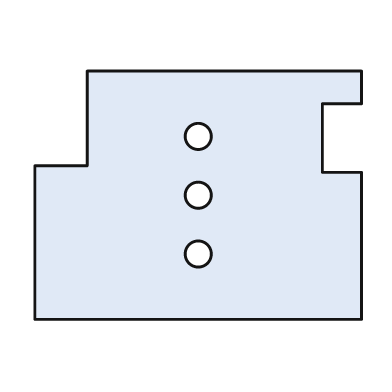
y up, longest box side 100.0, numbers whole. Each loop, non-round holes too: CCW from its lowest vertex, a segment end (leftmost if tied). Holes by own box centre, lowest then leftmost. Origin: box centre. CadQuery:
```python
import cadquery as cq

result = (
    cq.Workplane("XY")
    .moveTo(-50.0, -38.0)
    .lineTo(50.0, -38.0)
    .lineTo(50.0, 7.0)
    .lineTo(38.0, 7.0)
    .lineTo(38.0, 28.0)
    .lineTo(50.0, 28.0)
    .lineTo(50.0, 38.0)
    .lineTo(-34.0, 38.0)
    .lineTo(-34.0, 9.0)
    .lineTo(-50.0, 9.0)
    .close()
    .moveTo(0.0, -18.0)
    .circle(4.0)
    .moveTo(0.0, 0.0)
    .circle(4.0)
    .moveTo(0.0, 18.0)
    .circle(4.0)
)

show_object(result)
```